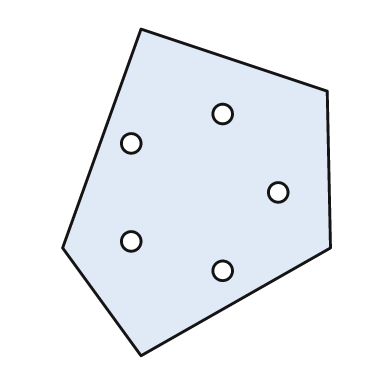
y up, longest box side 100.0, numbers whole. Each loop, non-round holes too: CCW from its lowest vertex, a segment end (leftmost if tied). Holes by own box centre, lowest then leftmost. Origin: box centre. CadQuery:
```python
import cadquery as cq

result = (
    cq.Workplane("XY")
    .moveTo(-17.0, -50.0)
    .lineTo(41.0, -17.0)
    .lineTo(40.0, 31.0)
    .lineTo(-17.0, 50.0)
    .lineTo(-41.0, -17.0)
    .close()
    .moveTo(8.0, -24.0)
    .circle(3.0)
    .moveTo(-20.0, -15.0)
    .circle(3.0)
    .moveTo(25.0, 0.0)
    .circle(3.0)
    .moveTo(-20.0, 15.0)
    .circle(3.0)
    .moveTo(8.0, 24.0)
    .circle(3.0)
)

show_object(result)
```